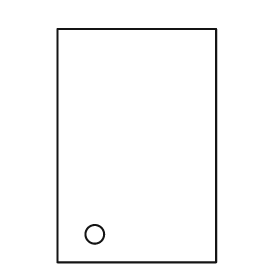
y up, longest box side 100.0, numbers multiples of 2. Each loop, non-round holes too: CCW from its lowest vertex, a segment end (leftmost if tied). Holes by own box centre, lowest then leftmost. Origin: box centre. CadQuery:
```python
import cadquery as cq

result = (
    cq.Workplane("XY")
    .moveTo(-34.0, -50.0)
    .lineTo(34.0, -50.0)
    .lineTo(34.0, 50.0)
    .lineTo(-34.0, 50.0)
    .close()
    .moveTo(-18.0, -38.0)
    .circle(4.0)
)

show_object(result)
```